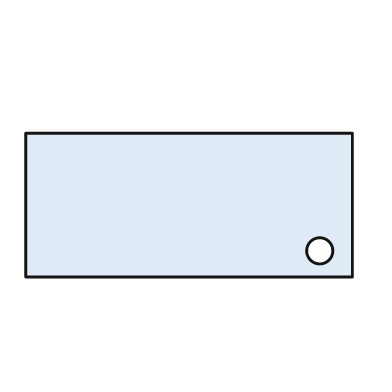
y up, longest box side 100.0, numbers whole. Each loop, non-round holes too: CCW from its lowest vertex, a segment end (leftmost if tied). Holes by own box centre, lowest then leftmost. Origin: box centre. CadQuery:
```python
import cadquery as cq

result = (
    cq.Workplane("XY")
    .moveTo(-50.0, -22.0)
    .lineTo(50.0, -22.0)
    .lineTo(50.0, 22.0)
    .lineTo(-50.0, 22.0)
    .close()
    .moveTo(40.0, -14.0)
    .circle(4.0)
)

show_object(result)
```